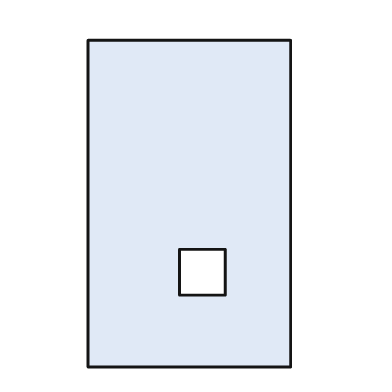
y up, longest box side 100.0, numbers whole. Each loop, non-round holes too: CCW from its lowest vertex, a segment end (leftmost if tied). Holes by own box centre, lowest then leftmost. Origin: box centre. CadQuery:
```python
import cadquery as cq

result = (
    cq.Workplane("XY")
    .moveTo(-31.0, -50.0)
    .lineTo(31.0, -50.0)
    .lineTo(31.0, 50.0)
    .lineTo(-31.0, 50.0)
    .close()
    .moveTo(-3.0, -28.0)
    .lineTo(11.0, -28.0)
    .lineTo(11.0, -14.0)
    .lineTo(-3.0, -14.0)
    .close()
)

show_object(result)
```